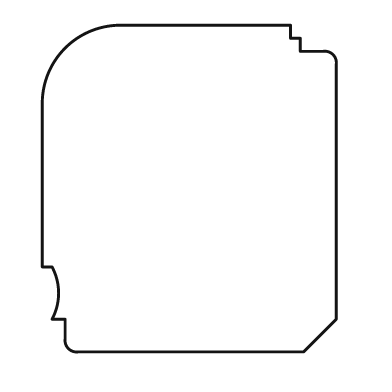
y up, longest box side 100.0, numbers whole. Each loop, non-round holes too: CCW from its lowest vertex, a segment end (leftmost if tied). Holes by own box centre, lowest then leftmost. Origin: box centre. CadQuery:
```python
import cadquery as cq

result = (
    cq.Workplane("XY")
    .moveTo(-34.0, -50.0)
    .lineTo(35.0, -50.0)
    .lineTo(45.0, -40.0)
    .lineTo(45.0, 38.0)
    .threePointArc((44.0, 41.0), (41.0, 42.0))
    .lineTo(34.0, 42.0)
    .lineTo(34.0, 46.0)
    .lineTo(31.0, 46.0)
    .lineTo(31.0, 50.0)
    .lineTo(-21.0, 50.0)
    .threePointArc((-38.0, 43.0), (-45.0, 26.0))
    .lineTo(-45.0, -24.0)
    .lineTo(-42.0, -24.0)
    .threePointArc((-40.0, -32.0), (-42.0, -40.0))
    .lineTo(-38.0, -40.0)
    .lineTo(-38.0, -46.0)
    .threePointArc((-37.0, -49.0), (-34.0, -50.0))
    .close()
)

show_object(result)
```